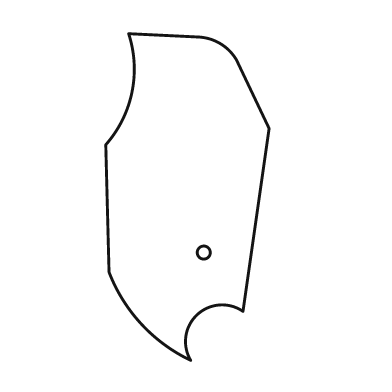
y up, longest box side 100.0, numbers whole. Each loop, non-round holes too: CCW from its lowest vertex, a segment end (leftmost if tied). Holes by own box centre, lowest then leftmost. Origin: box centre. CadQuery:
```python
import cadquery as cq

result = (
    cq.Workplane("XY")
    .moveTo(1.0, -50.0)
    .threePointArc((3.0, -36.0), (17.0, -35.0))
    .lineTo(25.0, 21.0)
    .lineTo(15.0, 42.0)
    .threePointArc((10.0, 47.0), (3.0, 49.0))
    .lineTo(-18.0, 50.0)
    .threePointArc((-17.0, 32.0), (-25.0, 16.0))
    .lineTo(-24.0, -23.0)
    .threePointArc((-14.0, -39.0), (1.0, -50.0))
    .close()
    .moveTo(5.0, -17.0)
    .circle(2.0)
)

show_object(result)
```